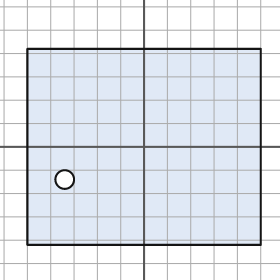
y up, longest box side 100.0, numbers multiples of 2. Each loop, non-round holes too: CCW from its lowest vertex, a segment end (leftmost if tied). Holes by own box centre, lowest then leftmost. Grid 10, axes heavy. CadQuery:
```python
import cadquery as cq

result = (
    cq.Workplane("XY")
    .moveTo(-50.0, -42.0)
    .lineTo(50.0, -42.0)
    .lineTo(50.0, 42.0)
    .lineTo(-50.0, 42.0)
    .close()
    .moveTo(-34.0, -14.0)
    .circle(4.0)
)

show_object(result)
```